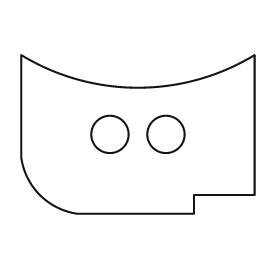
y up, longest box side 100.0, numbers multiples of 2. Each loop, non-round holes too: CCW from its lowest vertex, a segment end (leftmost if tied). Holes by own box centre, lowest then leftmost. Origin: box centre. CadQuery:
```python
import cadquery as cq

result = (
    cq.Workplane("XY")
    .moveTo(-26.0, -34.0)
    .lineTo(24.0, -34.0)
    .lineTo(24.0, -26.0)
    .lineTo(50.0, -26.0)
    .lineTo(50.0, 34.0)
    .threePointArc((0.0, 20.0), (-50.0, 34.0))
    .lineTo(-50.0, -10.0)
    .threePointArc((-42.0, -26.0), (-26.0, -34.0))
    .close()
    .moveTo(-12.0, 0.0)
    .circle(8.0)
    .moveTo(12.0, 0.0)
    .circle(8.0)
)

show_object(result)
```